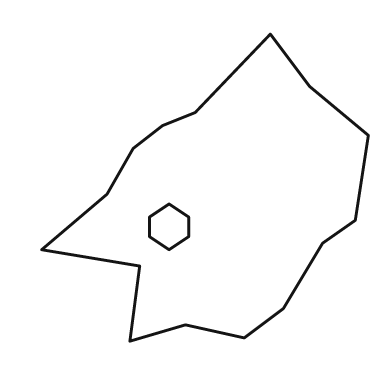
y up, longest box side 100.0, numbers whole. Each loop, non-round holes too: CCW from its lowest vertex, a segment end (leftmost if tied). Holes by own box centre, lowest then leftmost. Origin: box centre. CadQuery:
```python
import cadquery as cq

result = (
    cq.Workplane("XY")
    .moveTo(-23.0, -47.0)
    .lineTo(-6.0, -42.0)
    .lineTo(12.0, -46.0)
    .lineTo(24.0, -37.0)
    .lineTo(36.0, -17.0)
    .lineTo(46.0, -10.0)
    .lineTo(50.0, 16.0)
    .lineTo(32.0, 31.0)
    .lineTo(20.0, 47.0)
    .lineTo(-3.0, 23.0)
    .lineTo(-13.0, 19.0)
    .lineTo(-22.0, 12.0)
    .lineTo(-30.0, -2.0)
    .lineTo(-50.0, -19.0)
    .lineTo(-20.0, -24.0)
    .close()
    .moveTo(-11.0, -19.0)
    .lineTo(-5.0, -15.0)
    .lineTo(-5.0, -9.0)
    .lineTo(-11.0, -5.0)
    .lineTo(-17.0, -9.0)
    .lineTo(-17.0, -15.0)
    .close()
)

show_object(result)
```